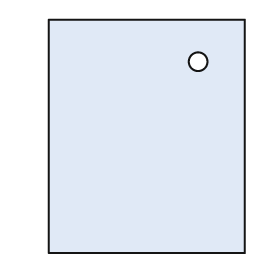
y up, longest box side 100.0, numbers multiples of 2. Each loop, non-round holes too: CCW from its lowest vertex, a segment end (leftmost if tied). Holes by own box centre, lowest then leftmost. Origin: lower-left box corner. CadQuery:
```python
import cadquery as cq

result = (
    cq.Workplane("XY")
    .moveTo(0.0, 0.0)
    .lineTo(84.0, 0.0)
    .lineTo(84.0, 100.0)
    .lineTo(0.0, 100.0)
    .close()
    .moveTo(64.0, 82.0)
    .circle(4.0)
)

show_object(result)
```